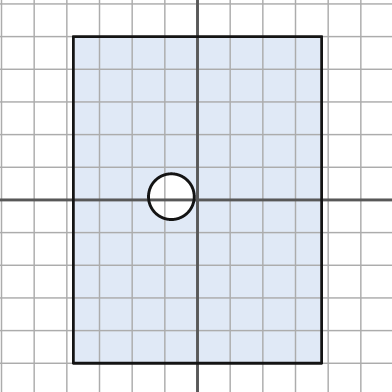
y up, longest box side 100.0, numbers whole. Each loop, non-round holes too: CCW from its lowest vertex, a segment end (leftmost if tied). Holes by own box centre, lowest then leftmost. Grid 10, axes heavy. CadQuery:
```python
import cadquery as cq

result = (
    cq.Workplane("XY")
    .moveTo(-38.0, -50.0)
    .lineTo(38.0, -50.0)
    .lineTo(38.0, 50.0)
    .lineTo(-38.0, 50.0)
    .close()
    .moveTo(-8.0, 1.0)
    .circle(7.0)
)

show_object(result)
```